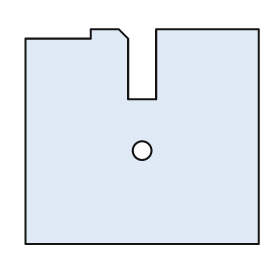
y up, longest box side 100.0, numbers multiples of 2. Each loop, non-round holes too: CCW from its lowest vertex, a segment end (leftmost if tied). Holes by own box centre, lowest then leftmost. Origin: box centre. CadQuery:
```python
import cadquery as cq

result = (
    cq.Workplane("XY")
    .moveTo(-50.0, -46.0)
    .lineTo(50.0, -46.0)
    .lineTo(50.0, 46.0)
    .lineTo(6.0, 46.0)
    .lineTo(6.0, 16.0)
    .lineTo(-6.0, 16.0)
    .lineTo(-6.0, 42.0)
    .lineTo(-10.0, 46.0)
    .lineTo(-22.0, 46.0)
    .lineTo(-22.0, 42.0)
    .lineTo(-50.0, 42.0)
    .close()
    .moveTo(0.0, -6.0)
    .circle(4.0)
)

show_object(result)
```